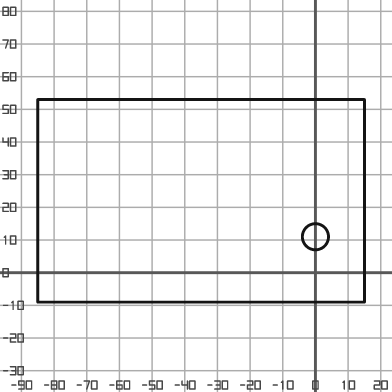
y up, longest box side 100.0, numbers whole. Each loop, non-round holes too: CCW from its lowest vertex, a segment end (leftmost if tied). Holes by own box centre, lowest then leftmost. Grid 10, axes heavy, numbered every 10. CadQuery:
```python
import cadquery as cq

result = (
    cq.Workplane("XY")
    .moveTo(-85.0, -9.0)
    .lineTo(15.0, -9.0)
    .lineTo(15.0, 53.0)
    .lineTo(-85.0, 53.0)
    .close()
    .moveTo(0.0, 11.0)
    .circle(4.0)
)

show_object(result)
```